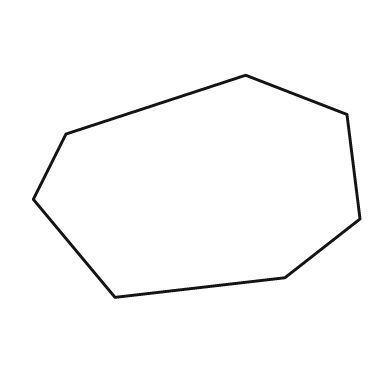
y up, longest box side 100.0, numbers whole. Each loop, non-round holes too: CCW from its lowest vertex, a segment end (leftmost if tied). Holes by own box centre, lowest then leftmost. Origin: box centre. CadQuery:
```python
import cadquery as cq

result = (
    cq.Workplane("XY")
    .moveTo(-25.0, -34.0)
    .lineTo(27.0, -28.0)
    .lineTo(50.0, -10.0)
    .lineTo(46.0, 22.0)
    .lineTo(15.0, 34.0)
    .lineTo(-40.0, 16.0)
    .lineTo(-50.0, -4.0)
    .close()
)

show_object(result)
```